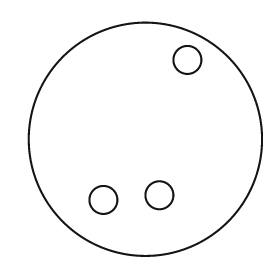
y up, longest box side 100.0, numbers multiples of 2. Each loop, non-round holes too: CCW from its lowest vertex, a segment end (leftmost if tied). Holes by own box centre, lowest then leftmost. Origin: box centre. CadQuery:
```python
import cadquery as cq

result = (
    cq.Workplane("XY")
    .moveTo(0.0, 0.0)
    .circle(50.0)
    .moveTo(-18.0, -26.0)
    .circle(6.0)
    .moveTo(6.0, -24.0)
    .circle(6.0)
    .moveTo(18.0, 34.0)
    .circle(6.0)
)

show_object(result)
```